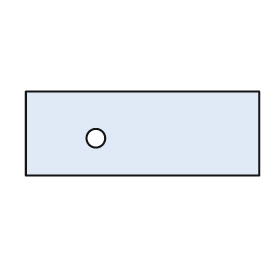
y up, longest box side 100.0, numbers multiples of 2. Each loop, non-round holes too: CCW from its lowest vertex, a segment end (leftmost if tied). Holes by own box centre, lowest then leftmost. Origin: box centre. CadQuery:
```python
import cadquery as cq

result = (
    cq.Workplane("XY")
    .moveTo(-50.0, -18.0)
    .lineTo(50.0, -18.0)
    .lineTo(50.0, 18.0)
    .lineTo(-50.0, 18.0)
    .close()
    .moveTo(-20.0, -2.0)
    .circle(4.0)
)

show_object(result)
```